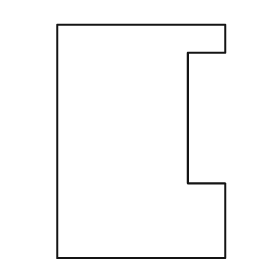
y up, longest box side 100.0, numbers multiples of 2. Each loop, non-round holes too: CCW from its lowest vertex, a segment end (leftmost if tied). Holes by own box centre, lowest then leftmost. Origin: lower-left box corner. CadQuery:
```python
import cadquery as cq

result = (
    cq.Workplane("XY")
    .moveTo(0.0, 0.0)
    .lineTo(72.0, 0.0)
    .lineTo(72.0, 32.0)
    .lineTo(56.0, 32.0)
    .lineTo(56.0, 88.0)
    .lineTo(72.0, 88.0)
    .lineTo(72.0, 100.0)
    .lineTo(0.0, 100.0)
    .close()
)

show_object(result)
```